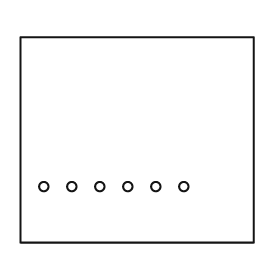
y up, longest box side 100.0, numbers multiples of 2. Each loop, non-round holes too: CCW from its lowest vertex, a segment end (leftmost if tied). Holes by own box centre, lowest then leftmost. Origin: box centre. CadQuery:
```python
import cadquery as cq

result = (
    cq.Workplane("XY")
    .moveTo(-50.0, -44.0)
    .lineTo(50.0, -44.0)
    .lineTo(50.0, 44.0)
    .lineTo(-50.0, 44.0)
    .close()
    .moveTo(-40.0, -20.0)
    .circle(2.0)
    .moveTo(-28.0, -20.0)
    .circle(2.0)
    .moveTo(-16.0, -20.0)
    .circle(2.0)
    .moveTo(-4.0, -20.0)
    .circle(2.0)
    .moveTo(8.0, -20.0)
    .circle(2.0)
    .moveTo(20.0, -20.0)
    .circle(2.0)
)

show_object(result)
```